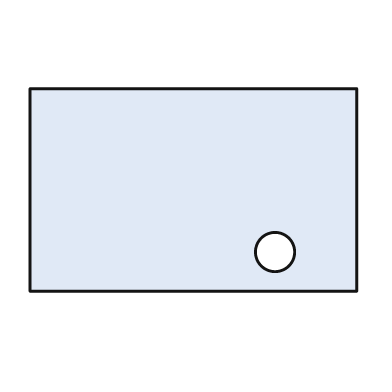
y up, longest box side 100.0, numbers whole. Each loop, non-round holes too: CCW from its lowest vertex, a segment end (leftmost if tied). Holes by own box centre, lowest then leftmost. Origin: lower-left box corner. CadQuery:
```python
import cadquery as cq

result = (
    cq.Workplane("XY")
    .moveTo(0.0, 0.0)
    .lineTo(100.0, 0.0)
    .lineTo(100.0, 62.0)
    .lineTo(0.0, 62.0)
    .close()
    .moveTo(75.0, 12.0)
    .circle(6.0)
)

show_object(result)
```